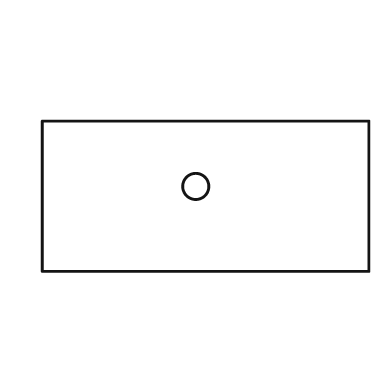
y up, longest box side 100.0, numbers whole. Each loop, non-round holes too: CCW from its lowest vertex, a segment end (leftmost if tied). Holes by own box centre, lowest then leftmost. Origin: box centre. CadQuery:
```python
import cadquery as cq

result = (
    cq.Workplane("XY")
    .moveTo(-50.0, -23.0)
    .lineTo(50.0, -23.0)
    .lineTo(50.0, 23.0)
    .lineTo(-50.0, 23.0)
    .close()
    .moveTo(-3.0, 3.0)
    .circle(4.0)
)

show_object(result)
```